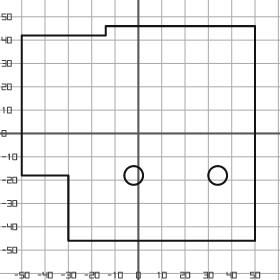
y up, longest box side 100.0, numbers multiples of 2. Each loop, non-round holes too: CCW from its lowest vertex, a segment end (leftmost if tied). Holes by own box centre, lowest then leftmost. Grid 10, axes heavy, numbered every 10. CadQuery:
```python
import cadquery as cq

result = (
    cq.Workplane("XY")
    .moveTo(-30.0, -46.0)
    .lineTo(50.0, -46.0)
    .lineTo(50.0, 46.0)
    .lineTo(-14.0, 46.0)
    .lineTo(-14.0, 42.0)
    .lineTo(-50.0, 42.0)
    .lineTo(-50.0, -18.0)
    .lineTo(-30.0, -18.0)
    .close()
    .moveTo(-2.0, -18.0)
    .circle(4.0)
    .moveTo(34.0, -18.0)
    .circle(4.0)
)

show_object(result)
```